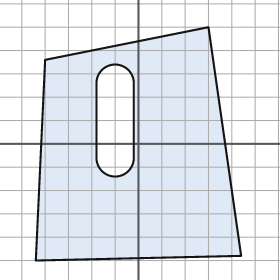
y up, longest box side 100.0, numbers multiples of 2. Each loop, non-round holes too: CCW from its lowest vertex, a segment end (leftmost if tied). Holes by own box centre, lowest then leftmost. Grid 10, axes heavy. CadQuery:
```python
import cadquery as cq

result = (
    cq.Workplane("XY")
    .moveTo(-44.0, -50.0)
    .lineTo(44.0, -48.0)
    .lineTo(30.0, 50.0)
    .lineTo(-40.0, 36.0)
    .close()
    .moveTo(-18.0, -6.0)
    .threePointArc((-10.0, -14.0), (-2.0, -6.0))
    .lineTo(-2.0, 26.0)
    .threePointArc((-10.0, 34.0), (-18.0, 26.0))
    .close()
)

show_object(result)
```